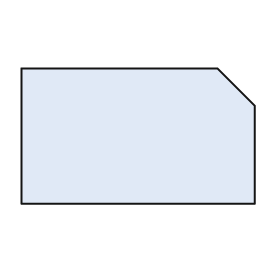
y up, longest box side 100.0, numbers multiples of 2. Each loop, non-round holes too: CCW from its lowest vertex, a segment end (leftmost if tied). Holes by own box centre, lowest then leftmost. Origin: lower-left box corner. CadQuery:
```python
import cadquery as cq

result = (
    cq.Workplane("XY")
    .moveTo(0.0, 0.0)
    .lineTo(100.0, 0.0)
    .lineTo(100.0, 42.0)
    .lineTo(84.0, 58.0)
    .lineTo(0.0, 58.0)
    .close()
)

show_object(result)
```